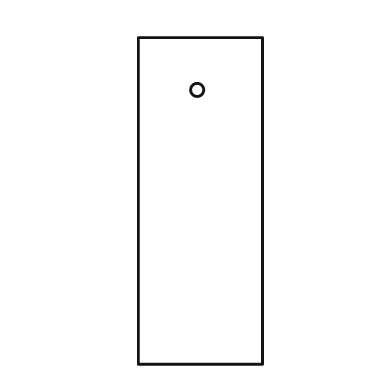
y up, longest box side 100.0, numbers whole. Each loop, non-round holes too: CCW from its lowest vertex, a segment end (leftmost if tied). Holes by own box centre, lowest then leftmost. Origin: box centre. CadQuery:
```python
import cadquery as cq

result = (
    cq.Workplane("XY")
    .moveTo(-19.0, -50.0)
    .lineTo(19.0, -50.0)
    .lineTo(19.0, 50.0)
    .lineTo(-19.0, 50.0)
    .close()
    .moveTo(-1.0, 34.0)
    .circle(2.0)
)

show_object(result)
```